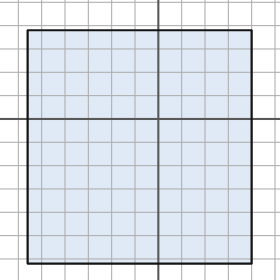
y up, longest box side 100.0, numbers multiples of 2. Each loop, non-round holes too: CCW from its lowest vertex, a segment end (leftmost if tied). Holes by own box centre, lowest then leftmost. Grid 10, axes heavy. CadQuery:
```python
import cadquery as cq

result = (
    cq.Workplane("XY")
    .moveTo(-56.0, -62.0)
    .lineTo(40.0, -62.0)
    .lineTo(40.0, 38.0)
    .lineTo(-56.0, 38.0)
    .close()
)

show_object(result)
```